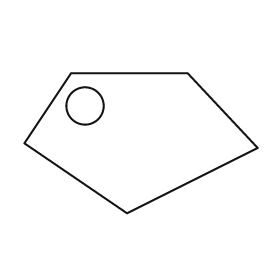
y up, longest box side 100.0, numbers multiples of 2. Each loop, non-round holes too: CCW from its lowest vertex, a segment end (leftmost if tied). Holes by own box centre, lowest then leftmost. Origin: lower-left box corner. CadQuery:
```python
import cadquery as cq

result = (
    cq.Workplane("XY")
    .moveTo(44.0, 0.0)
    .lineTo(100.0, 28.0)
    .lineTo(70.0, 60.0)
    .lineTo(20.0, 60.0)
    .lineTo(0.0, 30.0)
    .close()
    .moveTo(26.0, 46.0)
    .circle(8.0)
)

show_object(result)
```